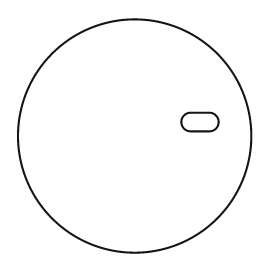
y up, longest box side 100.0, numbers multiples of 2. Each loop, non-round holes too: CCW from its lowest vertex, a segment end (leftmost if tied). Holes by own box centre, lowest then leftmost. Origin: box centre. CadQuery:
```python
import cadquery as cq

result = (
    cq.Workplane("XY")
    .moveTo(0.0, 0.0)
    .circle(50.0)
    .moveTo(24.0, 2.0)
    .lineTo(32.0, 2.0)
    .threePointArc((36.0, 6.0), (32.0, 10.0))
    .lineTo(24.0, 10.0)
    .threePointArc((20.0, 6.0), (24.0, 2.0))
    .close()
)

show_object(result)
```